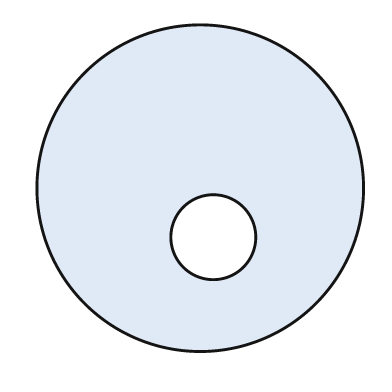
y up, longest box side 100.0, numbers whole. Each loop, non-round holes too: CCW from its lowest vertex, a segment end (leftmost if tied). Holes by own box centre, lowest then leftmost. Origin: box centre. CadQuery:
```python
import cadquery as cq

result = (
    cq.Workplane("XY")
    .moveTo(0.0, 0.0)
    .circle(50.0)
    .moveTo(4.0, -15.0)
    .circle(13.0)
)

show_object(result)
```